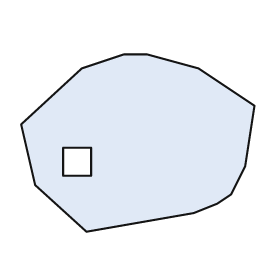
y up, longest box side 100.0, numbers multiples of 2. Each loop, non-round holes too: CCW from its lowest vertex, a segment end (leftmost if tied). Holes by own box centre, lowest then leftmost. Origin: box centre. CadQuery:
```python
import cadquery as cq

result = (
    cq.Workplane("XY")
    .moveTo(-22.0, -38.0)
    .lineTo(24.0, -30.0)
    .lineTo(34.0, -26.0)
    .lineTo(40.0, -22.0)
    .lineTo(46.0, -10.0)
    .lineTo(50.0, 16.0)
    .lineTo(26.0, 32.0)
    .lineTo(4.0, 38.0)
    .lineTo(-6.0, 38.0)
    .lineTo(-24.0, 32.0)
    .lineTo(-50.0, 8.0)
    .lineTo(-44.0, -18.0)
    .close()
    .moveTo(-32.0, -14.0)
    .lineTo(-20.0, -14.0)
    .lineTo(-20.0, -2.0)
    .lineTo(-32.0, -2.0)
    .close()
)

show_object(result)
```